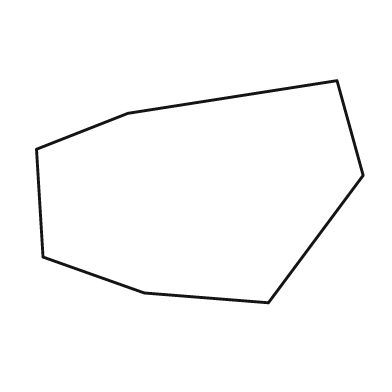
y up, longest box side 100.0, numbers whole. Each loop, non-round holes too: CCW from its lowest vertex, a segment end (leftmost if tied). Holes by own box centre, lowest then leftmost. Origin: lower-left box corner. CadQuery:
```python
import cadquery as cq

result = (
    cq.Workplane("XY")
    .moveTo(71.0, 0.0)
    .lineTo(100.0, 39.0)
    .lineTo(92.0, 68.0)
    .lineTo(28.0, 58.0)
    .lineTo(0.0, 47.0)
    .lineTo(2.0, 14.0)
    .lineTo(33.0, 3.0)
    .close()
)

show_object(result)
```